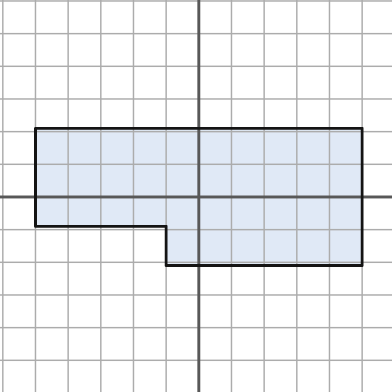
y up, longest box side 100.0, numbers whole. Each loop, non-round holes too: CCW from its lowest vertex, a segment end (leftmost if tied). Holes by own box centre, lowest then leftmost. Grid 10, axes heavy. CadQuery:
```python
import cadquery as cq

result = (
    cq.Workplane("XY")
    .moveTo(-10.0, -21.0)
    .lineTo(50.0, -21.0)
    .lineTo(50.0, 21.0)
    .lineTo(-50.0, 21.0)
    .lineTo(-50.0, -9.0)
    .lineTo(-10.0, -9.0)
    .close()
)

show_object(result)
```